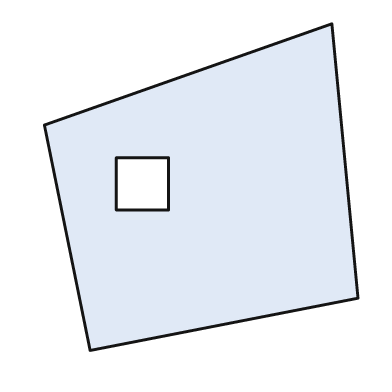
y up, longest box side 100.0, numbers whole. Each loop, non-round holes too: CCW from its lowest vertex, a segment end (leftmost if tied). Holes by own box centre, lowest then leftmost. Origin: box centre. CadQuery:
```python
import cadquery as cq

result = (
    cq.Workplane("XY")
    .moveTo(-34.0, -50.0)
    .lineTo(48.0, -34.0)
    .lineTo(40.0, 50.0)
    .lineTo(-48.0, 19.0)
    .close()
    .moveTo(-26.0, -7.0)
    .lineTo(-10.0, -7.0)
    .lineTo(-10.0, 9.0)
    .lineTo(-26.0, 9.0)
    .close()
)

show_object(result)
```